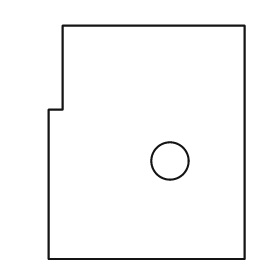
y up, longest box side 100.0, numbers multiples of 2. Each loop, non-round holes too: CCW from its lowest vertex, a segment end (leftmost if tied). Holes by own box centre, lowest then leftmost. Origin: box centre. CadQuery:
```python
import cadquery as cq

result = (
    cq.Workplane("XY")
    .moveTo(-42.0, -50.0)
    .lineTo(42.0, -50.0)
    .lineTo(42.0, 50.0)
    .lineTo(-36.0, 50.0)
    .lineTo(-36.0, 14.0)
    .lineTo(-42.0, 14.0)
    .close()
    .moveTo(10.0, -8.0)
    .circle(8.0)
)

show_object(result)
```